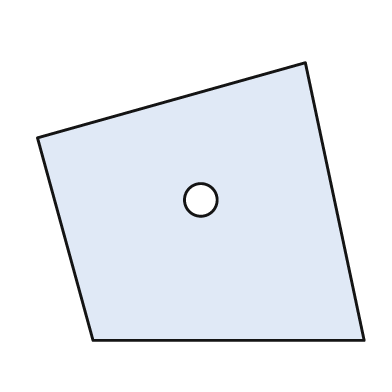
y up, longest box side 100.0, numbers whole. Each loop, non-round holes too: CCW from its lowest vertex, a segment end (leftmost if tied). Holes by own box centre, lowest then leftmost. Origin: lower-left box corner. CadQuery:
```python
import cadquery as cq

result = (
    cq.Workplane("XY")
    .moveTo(17.0, 0.0)
    .lineTo(100.0, 0.0)
    .lineTo(82.0, 85.0)
    .lineTo(0.0, 62.0)
    .close()
    .moveTo(50.0, 43.0)
    .circle(5.0)
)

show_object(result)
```